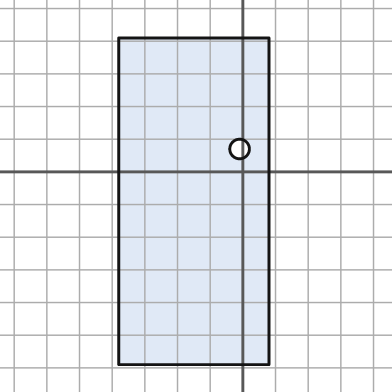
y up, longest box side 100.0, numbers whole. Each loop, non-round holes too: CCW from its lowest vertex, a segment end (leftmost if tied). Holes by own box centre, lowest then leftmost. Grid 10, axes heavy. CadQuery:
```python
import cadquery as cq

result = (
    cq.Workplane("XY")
    .moveTo(-38.0, -59.0)
    .lineTo(8.0, -59.0)
    .lineTo(8.0, 41.0)
    .lineTo(-38.0, 41.0)
    .close()
    .moveTo(-1.0, 7.0)
    .circle(3.0)
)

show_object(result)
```